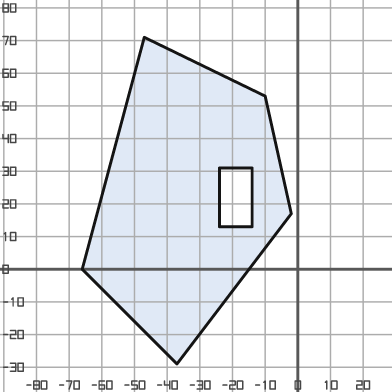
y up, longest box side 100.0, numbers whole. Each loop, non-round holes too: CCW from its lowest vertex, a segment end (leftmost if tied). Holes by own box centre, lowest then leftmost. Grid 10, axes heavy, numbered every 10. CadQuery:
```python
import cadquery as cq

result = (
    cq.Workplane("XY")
    .moveTo(-37.0, -29.0)
    .lineTo(-2.0, 17.0)
    .lineTo(-10.0, 53.0)
    .lineTo(-47.0, 71.0)
    .lineTo(-66.0, 0.0)
    .close()
    .moveTo(-24.0, 13.0)
    .lineTo(-14.0, 13.0)
    .lineTo(-14.0, 31.0)
    .lineTo(-24.0, 31.0)
    .close()
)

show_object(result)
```